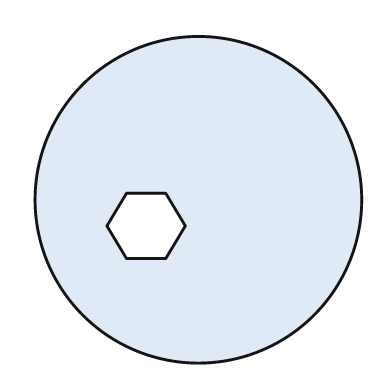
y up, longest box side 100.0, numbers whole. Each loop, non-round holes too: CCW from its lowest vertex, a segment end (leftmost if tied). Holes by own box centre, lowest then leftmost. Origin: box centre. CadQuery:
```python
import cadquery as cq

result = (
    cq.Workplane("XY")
    .moveTo(0.0, 0.0)
    .circle(50.0)
    .moveTo(-22.0, -18.0)
    .lineTo(-10.0, -18.0)
    .lineTo(-4.0, -8.0)
    .lineTo(-10.0, 2.0)
    .lineTo(-22.0, 2.0)
    .lineTo(-28.0, -8.0)
    .close()
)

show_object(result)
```